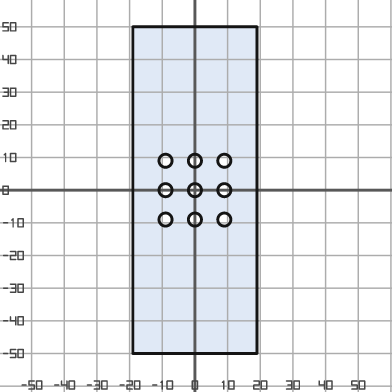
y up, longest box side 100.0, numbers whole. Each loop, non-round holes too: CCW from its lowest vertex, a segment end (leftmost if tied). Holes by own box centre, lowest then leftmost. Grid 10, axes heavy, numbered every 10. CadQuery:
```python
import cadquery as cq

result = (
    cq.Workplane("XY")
    .moveTo(-19.0, -50.0)
    .lineTo(19.0, -50.0)
    .lineTo(19.0, 50.0)
    .lineTo(-19.0, 50.0)
    .close()
    .moveTo(-9.0, -9.0)
    .circle(2.0)
    .moveTo(0.0, -9.0)
    .circle(2.0)
    .moveTo(9.0, -9.0)
    .circle(2.0)
    .moveTo(-9.0, 0.0)
    .circle(2.0)
    .moveTo(0.0, 0.0)
    .circle(2.0)
    .moveTo(9.0, 0.0)
    .circle(2.0)
    .moveTo(-9.0, 9.0)
    .circle(2.0)
    .moveTo(0.0, 9.0)
    .circle(2.0)
    .moveTo(9.0, 9.0)
    .circle(2.0)
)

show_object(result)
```